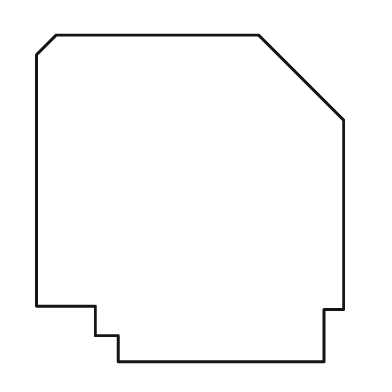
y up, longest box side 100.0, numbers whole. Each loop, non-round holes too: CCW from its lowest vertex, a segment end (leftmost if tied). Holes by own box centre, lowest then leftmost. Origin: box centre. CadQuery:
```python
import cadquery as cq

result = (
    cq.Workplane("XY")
    .moveTo(-22.0, -50.0)
    .lineTo(41.0, -50.0)
    .lineTo(41.0, -34.0)
    .lineTo(47.0, -34.0)
    .lineTo(47.0, 24.0)
    .lineTo(21.0, 50.0)
    .lineTo(-41.0, 50.0)
    .lineTo(-47.0, 44.0)
    .lineTo(-47.0, -33.0)
    .lineTo(-29.0, -33.0)
    .lineTo(-29.0, -42.0)
    .lineTo(-22.0, -42.0)
    .close()
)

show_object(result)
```